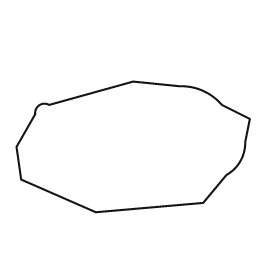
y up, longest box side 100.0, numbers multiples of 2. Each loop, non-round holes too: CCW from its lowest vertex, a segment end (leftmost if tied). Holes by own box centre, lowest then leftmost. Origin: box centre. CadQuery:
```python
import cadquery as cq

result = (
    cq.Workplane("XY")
    .moveTo(-16.0, -28.0)
    .lineTo(30.0, -24.0)
    .lineTo(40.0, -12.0)
    .threePointArc((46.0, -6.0), (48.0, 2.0))
    .lineTo(50.0, 12.0)
    .lineTo(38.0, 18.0)
    .threePointArc((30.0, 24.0), (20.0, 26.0))
    .lineTo(0.0, 28.0)
    .lineTo(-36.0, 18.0)
    .threePointArc((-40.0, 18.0), (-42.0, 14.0))
    .lineTo(-50.0, 0.0)
    .lineTo(-48.0, -14.0)
    .close()
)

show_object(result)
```